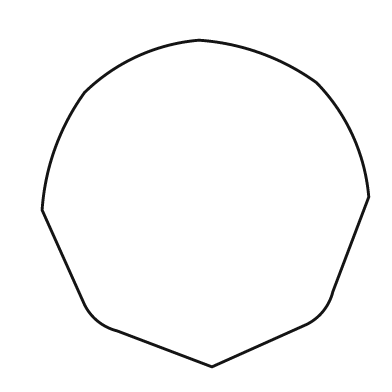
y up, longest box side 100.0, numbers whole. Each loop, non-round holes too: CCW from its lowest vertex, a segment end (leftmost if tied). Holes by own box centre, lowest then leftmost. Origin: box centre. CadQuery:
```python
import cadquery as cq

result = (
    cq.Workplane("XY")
    .moveTo(2.0, -50.0)
    .lineTo(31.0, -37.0)
    .threePointArc((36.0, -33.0), (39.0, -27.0))
    .lineTo(50.0, 2.0)
    .threePointArc((45.0, 21.0), (34.0, 37.0))
    .threePointArc((17.0, 46.0), (-2.0, 50.0))
    .threePointArc((-21.0, 45.0), (-37.0, 34.0))
    .threePointArc((-46.0, 17.0), (-50.0, -2.0))
    .lineTo(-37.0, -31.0)
    .threePointArc((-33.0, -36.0), (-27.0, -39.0))
    .close()
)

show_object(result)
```